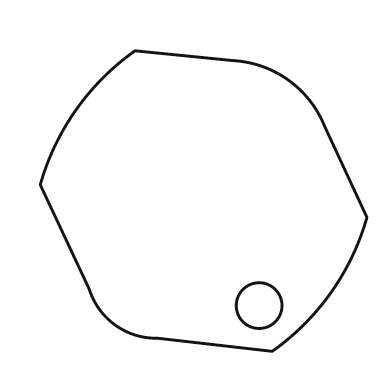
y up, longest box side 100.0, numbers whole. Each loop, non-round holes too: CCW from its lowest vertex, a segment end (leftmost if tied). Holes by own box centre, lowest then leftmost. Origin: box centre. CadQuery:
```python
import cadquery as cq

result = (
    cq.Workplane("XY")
    .moveTo(21.0, -46.0)
    .threePointArc((39.0, -28.0), (50.0, -5.0))
    .lineTo(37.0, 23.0)
    .threePointArc((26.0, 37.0), (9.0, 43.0))
    .lineTo(-21.0, 46.0)
    .threePointArc((-39.0, 28.0), (-50.0, 5.0))
    .lineTo(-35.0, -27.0)
    .threePointArc((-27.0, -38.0), (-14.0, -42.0))
    .close()
    .moveTo(17.0, -32.0)
    .circle(7.0)
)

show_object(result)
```